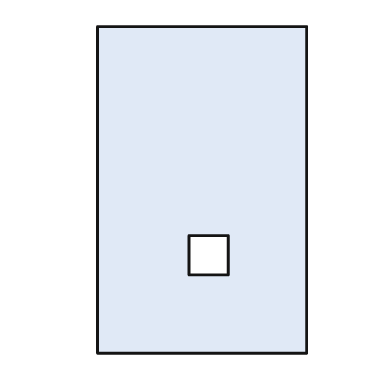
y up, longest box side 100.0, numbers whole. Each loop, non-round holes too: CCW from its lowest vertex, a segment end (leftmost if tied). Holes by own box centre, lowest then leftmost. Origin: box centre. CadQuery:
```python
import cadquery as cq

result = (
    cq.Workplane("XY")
    .moveTo(-32.0, -50.0)
    .lineTo(32.0, -50.0)
    .lineTo(32.0, 50.0)
    .lineTo(-32.0, 50.0)
    .close()
    .moveTo(-4.0, -26.0)
    .lineTo(8.0, -26.0)
    .lineTo(8.0, -14.0)
    .lineTo(-4.0, -14.0)
    .close()
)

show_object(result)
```